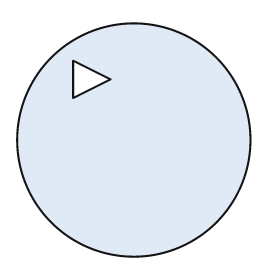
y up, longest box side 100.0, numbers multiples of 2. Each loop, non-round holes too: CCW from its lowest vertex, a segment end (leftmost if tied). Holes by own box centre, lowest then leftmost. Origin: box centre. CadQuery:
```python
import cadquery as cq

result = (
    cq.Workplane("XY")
    .moveTo(0.0, 0.0)
    .circle(50.0)
    .moveTo(-26.0, 18.0)
    .lineTo(-10.0, 26.0)
    .lineTo(-26.0, 34.0)
    .close()
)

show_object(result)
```